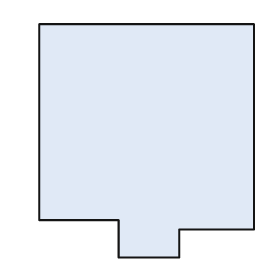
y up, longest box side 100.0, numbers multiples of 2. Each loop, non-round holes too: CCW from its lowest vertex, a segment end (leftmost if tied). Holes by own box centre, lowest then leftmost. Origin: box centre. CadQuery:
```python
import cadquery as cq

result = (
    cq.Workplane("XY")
    .moveTo(-12.0, -50.0)
    .lineTo(14.0, -50.0)
    .lineTo(14.0, -38.0)
    .lineTo(46.0, -38.0)
    .lineTo(46.0, 50.0)
    .lineTo(-46.0, 50.0)
    .lineTo(-46.0, -34.0)
    .lineTo(-12.0, -34.0)
    .close()
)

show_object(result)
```